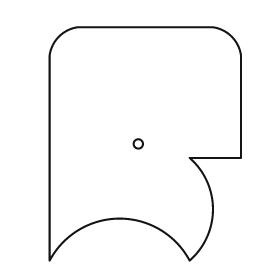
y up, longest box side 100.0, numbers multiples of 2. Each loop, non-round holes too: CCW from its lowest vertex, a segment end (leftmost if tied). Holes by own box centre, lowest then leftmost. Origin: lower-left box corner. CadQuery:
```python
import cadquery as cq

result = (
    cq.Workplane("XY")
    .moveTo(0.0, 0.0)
    .threePointArc((30.0, 18.0), (60.0, 0.0))
    .threePointArc((70.0, 22.0), (60.0, 44.0))
    .lineTo(82.0, 44.0)
    .lineTo(82.0, 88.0)
    .threePointArc((78.0, 96.0), (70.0, 100.0))
    .lineTo(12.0, 100.0)
    .threePointArc((4.0, 96.0), (0.0, 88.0))
    .close()
    .moveTo(38.0, 50.0)
    .circle(2.0)
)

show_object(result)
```